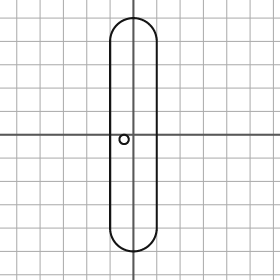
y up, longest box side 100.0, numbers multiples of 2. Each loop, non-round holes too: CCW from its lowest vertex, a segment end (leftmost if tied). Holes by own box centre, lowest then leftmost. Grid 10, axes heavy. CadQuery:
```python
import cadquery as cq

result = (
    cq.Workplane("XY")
    .moveTo(-10.0, -40.0)
    .threePointArc((0.0, -50.0), (10.0, -40.0))
    .lineTo(10.0, 40.0)
    .threePointArc((0.0, 50.0), (-10.0, 40.0))
    .close()
    .moveTo(-4.0, -2.0)
    .circle(2.0)
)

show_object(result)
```